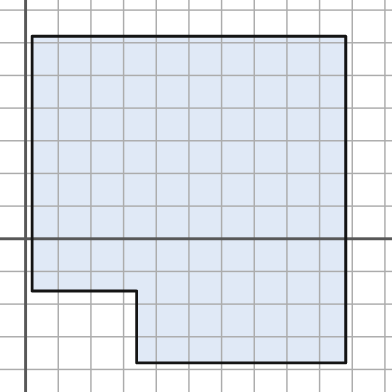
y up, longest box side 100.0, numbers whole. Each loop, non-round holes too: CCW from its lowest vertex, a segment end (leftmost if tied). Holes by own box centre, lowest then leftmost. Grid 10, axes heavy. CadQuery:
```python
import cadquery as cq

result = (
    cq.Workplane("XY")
    .moveTo(34.0, -38.0)
    .lineTo(98.0, -38.0)
    .lineTo(98.0, 62.0)
    .lineTo(2.0, 62.0)
    .lineTo(2.0, -16.0)
    .lineTo(34.0, -16.0)
    .close()
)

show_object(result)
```